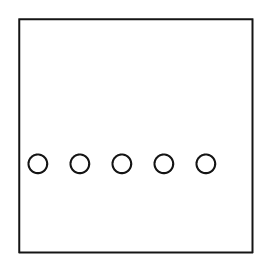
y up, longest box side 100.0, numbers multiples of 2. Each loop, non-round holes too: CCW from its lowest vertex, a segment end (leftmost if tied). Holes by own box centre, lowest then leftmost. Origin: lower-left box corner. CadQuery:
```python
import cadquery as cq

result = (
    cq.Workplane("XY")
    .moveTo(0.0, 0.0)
    .lineTo(100.0, 0.0)
    .lineTo(100.0, 100.0)
    .lineTo(0.0, 100.0)
    .close()
    .moveTo(8.0, 38.0)
    .circle(4.0)
    .moveTo(26.0, 38.0)
    .circle(4.0)
    .moveTo(44.0, 38.0)
    .circle(4.0)
    .moveTo(62.0, 38.0)
    .circle(4.0)
    .moveTo(80.0, 38.0)
    .circle(4.0)
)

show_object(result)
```